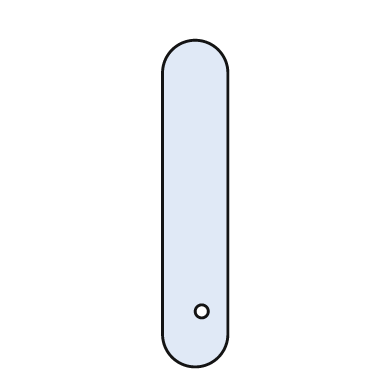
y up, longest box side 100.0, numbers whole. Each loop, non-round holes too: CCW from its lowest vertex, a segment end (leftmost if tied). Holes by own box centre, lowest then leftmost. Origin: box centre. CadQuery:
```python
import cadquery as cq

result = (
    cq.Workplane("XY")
    .moveTo(-10.0, -40.0)
    .threePointArc((0.0, -50.0), (10.0, -40.0))
    .lineTo(10.0, 40.0)
    .threePointArc((0.0, 50.0), (-10.0, 40.0))
    .close()
    .moveTo(2.0, -33.0)
    .circle(2.0)
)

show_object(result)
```